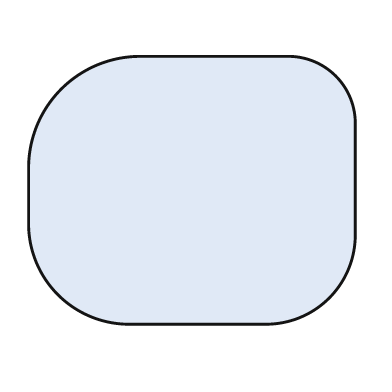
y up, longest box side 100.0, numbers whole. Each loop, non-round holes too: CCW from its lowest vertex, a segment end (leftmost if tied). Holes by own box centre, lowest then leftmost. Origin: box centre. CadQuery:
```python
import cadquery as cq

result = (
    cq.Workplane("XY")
    .moveTo(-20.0, -41.0)
    .lineTo(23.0, -41.0)
    .threePointArc((42.0, -33.0), (50.0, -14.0))
    .lineTo(50.0, 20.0)
    .threePointArc((44.0, 35.0), (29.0, 41.0))
    .lineTo(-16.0, 41.0)
    .threePointArc((-40.0, 31.0), (-50.0, 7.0))
    .lineTo(-50.0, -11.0)
    .threePointArc((-41.0, -32.0), (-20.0, -41.0))
    .close()
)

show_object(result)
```